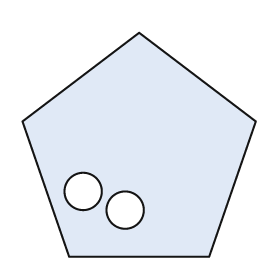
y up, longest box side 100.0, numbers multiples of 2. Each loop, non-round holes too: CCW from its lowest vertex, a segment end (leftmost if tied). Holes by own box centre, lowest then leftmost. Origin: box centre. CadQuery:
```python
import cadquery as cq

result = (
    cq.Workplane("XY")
    .moveTo(-30.0, -48.0)
    .lineTo(30.0, -48.0)
    .lineTo(50.0, 10.0)
    .lineTo(0.0, 48.0)
    .lineTo(-50.0, 10.0)
    .close()
    .moveTo(-6.0, -28.0)
    .circle(8.0)
    .moveTo(-24.0, -20.0)
    .circle(8.0)
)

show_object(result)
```